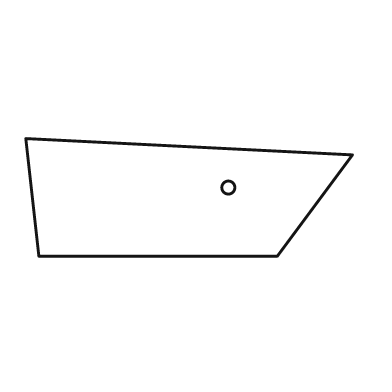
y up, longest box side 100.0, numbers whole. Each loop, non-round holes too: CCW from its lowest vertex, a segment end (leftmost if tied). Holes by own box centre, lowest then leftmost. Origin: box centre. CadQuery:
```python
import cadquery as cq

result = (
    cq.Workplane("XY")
    .moveTo(-46.0, -18.0)
    .lineTo(27.0, -18.0)
    .lineTo(50.0, 13.0)
    .lineTo(-50.0, 18.0)
    .close()
    .moveTo(12.0, 3.0)
    .circle(2.0)
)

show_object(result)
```